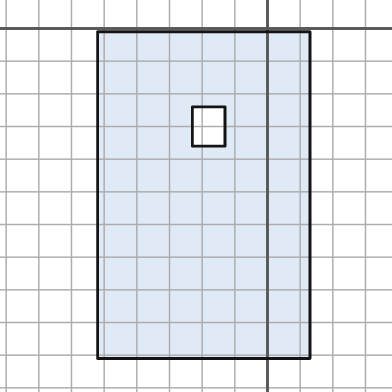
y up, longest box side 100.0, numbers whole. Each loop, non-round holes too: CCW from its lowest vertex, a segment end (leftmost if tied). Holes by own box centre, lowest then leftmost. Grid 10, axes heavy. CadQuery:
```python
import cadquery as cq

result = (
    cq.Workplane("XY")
    .moveTo(-52.0, -101.0)
    .lineTo(13.0, -101.0)
    .lineTo(13.0, -1.0)
    .lineTo(-52.0, -1.0)
    .close()
    .moveTo(-23.0, -36.0)
    .lineTo(-13.0, -36.0)
    .lineTo(-13.0, -24.0)
    .lineTo(-23.0, -24.0)
    .close()
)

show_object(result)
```